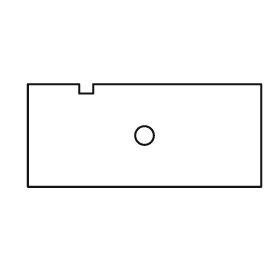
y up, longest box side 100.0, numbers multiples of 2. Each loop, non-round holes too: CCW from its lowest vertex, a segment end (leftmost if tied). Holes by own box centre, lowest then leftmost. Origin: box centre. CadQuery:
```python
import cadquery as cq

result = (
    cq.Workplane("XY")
    .moveTo(-50.0, -22.0)
    .lineTo(50.0, -22.0)
    .lineTo(50.0, 22.0)
    .lineTo(-22.0, 22.0)
    .lineTo(-22.0, 18.0)
    .lineTo(-28.0, 18.0)
    .lineTo(-28.0, 22.0)
    .lineTo(-50.0, 22.0)
    .close()
    .moveTo(0.0, 0.0)
    .circle(4.0)
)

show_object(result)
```